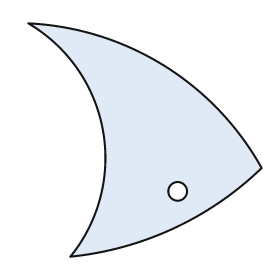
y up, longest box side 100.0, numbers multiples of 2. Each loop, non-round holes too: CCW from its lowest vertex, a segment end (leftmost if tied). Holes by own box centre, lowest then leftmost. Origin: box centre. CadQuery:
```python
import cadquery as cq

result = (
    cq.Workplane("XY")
    .moveTo(-32.0, -50.0)
    .threePointArc((12.0, -38.0), (50.0, -12.0))
    .threePointArc((8.0, 32.0), (-50.0, 50.0))
    .threePointArc((-18.0, 4.0), (-32.0, -50.0))
    .close()
    .moveTo(14.0, -22.0)
    .circle(4.0)
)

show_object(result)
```